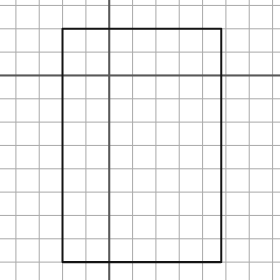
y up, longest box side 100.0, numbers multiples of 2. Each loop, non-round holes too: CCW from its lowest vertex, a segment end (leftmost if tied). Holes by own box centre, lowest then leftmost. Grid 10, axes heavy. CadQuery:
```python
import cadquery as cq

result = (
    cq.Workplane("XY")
    .moveTo(-20.0, -80.0)
    .lineTo(48.0, -80.0)
    .lineTo(48.0, 20.0)
    .lineTo(-20.0, 20.0)
    .close()
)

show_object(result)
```